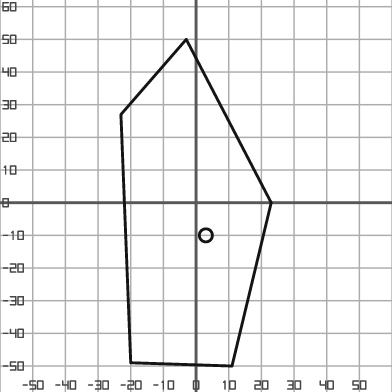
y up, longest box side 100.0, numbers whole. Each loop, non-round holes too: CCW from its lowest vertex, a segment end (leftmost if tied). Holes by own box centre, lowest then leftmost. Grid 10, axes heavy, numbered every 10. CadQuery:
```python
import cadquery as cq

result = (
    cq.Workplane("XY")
    .moveTo(11.0, -50.0)
    .lineTo(23.0, 0.0)
    .lineTo(-3.0, 50.0)
    .lineTo(-23.0, 27.0)
    .lineTo(-20.0, -49.0)
    .close()
    .moveTo(3.0, -10.0)
    .circle(2.0)
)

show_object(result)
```